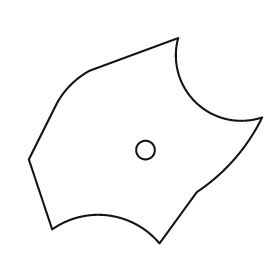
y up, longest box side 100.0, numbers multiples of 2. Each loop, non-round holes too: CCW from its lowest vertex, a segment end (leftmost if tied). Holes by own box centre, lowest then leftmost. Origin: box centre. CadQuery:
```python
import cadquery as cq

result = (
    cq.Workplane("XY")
    .moveTo(6.0, -44.0)
    .lineTo(22.0, -22.0)
    .threePointArc((38.0, -8.0), (50.0, 10.0))
    .threePointArc((22.0, 16.0), (14.0, 44.0))
    .lineTo(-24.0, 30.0)
    .threePointArc((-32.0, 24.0), (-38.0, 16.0))
    .lineTo(-50.0, -8.0)
    .lineTo(-40.0, -38.0)
    .threePointArc((-16.0, -32.0), (6.0, -44.0))
    .close()
    .moveTo(0.0, -4.0)
    .circle(4.0)
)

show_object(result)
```